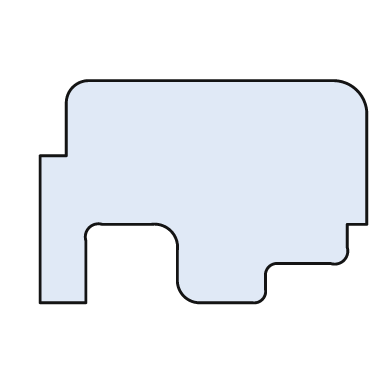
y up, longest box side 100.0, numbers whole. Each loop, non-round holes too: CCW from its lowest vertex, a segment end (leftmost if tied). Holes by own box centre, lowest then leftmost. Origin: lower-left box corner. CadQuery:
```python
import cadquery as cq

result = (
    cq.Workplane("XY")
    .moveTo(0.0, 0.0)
    .lineTo(14.0, 0.0)
    .lineTo(14.0, 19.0)
    .threePointArc((15.0, 23.0), (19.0, 24.0))
    .lineTo(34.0, 24.0)
    .threePointArc((40.0, 22.0), (42.0, 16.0))
    .lineTo(42.0, 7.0)
    .threePointArc((44.0, 2.0), (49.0, 0.0))
    .lineTo(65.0, 0.0)
    .threePointArc((68.0, 1.0), (69.0, 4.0))
    .lineTo(69.0, 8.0)
    .threePointArc((70.0, 11.0), (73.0, 12.0))
    .lineTo(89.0, 12.0)
    .threePointArc((93.0, 13.0), (94.0, 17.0))
    .lineTo(94.0, 24.0)
    .lineTo(100.0, 24.0)
    .lineTo(100.0, 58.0)
    .threePointArc((97.0, 65.0), (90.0, 68.0))
    .lineTo(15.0, 68.0)
    .threePointArc((10.0, 66.0), (8.0, 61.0))
    .lineTo(8.0, 45.0)
    .lineTo(0.0, 45.0)
    .close()
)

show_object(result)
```